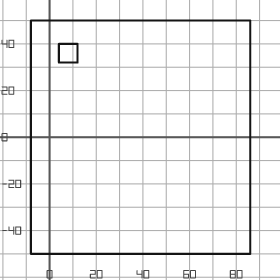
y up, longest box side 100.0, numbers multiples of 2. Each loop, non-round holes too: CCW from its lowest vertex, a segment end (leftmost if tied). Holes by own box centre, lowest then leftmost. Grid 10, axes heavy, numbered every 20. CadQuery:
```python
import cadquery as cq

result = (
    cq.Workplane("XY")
    .moveTo(-8.0, -50.0)
    .lineTo(86.0, -50.0)
    .lineTo(86.0, 50.0)
    .lineTo(-8.0, 50.0)
    .close()
    .moveTo(4.0, 32.0)
    .lineTo(12.0, 32.0)
    .lineTo(12.0, 40.0)
    .lineTo(4.0, 40.0)
    .close()
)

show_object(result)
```